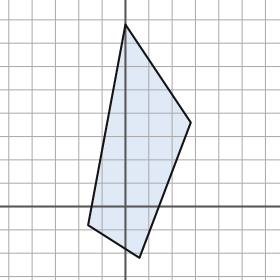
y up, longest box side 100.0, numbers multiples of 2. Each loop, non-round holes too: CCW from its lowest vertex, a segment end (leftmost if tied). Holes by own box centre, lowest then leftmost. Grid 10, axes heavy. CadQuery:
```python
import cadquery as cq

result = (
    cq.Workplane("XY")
    .moveTo(6.0, -22.0)
    .lineTo(28.0, 36.0)
    .lineTo(0.0, 78.0)
    .lineTo(-16.0, -8.0)
    .close()
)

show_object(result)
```